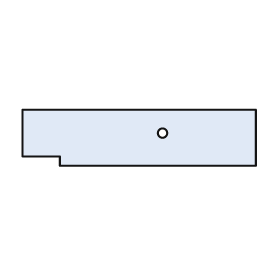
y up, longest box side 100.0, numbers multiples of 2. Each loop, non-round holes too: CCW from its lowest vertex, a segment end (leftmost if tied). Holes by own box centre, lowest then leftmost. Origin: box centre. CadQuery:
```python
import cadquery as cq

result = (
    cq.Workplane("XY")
    .moveTo(-34.0, -12.0)
    .lineTo(50.0, -12.0)
    .lineTo(50.0, 12.0)
    .lineTo(-50.0, 12.0)
    .lineTo(-50.0, -8.0)
    .lineTo(-34.0, -8.0)
    .close()
    .moveTo(10.0, 2.0)
    .circle(2.0)
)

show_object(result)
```